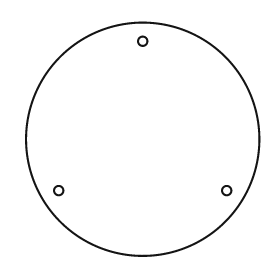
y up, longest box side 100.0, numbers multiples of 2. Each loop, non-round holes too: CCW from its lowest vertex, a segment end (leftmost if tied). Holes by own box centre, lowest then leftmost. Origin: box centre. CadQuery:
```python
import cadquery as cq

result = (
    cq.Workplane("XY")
    .moveTo(0.0, 0.0)
    .circle(50.0)
    .moveTo(-36.0, -22.0)
    .circle(2.0)
    .moveTo(36.0, -22.0)
    .circle(2.0)
    .moveTo(0.0, 42.0)
    .circle(2.0)
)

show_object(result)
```